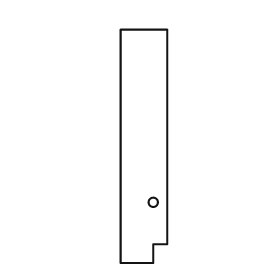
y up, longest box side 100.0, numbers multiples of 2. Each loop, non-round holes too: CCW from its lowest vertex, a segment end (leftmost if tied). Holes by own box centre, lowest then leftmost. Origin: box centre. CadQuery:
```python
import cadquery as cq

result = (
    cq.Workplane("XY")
    .moveTo(-10.0, -50.0)
    .lineTo(4.0, -50.0)
    .lineTo(4.0, -42.0)
    .lineTo(10.0, -42.0)
    .lineTo(10.0, 50.0)
    .lineTo(-10.0, 50.0)
    .close()
    .moveTo(4.0, -24.0)
    .circle(2.0)
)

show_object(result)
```